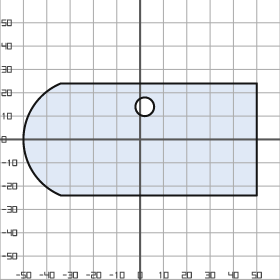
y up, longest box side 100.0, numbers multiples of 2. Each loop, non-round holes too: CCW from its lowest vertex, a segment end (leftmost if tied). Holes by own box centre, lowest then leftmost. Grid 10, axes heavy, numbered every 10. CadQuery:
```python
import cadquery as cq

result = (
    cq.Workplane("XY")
    .moveTo(-34.0, -24.0)
    .lineTo(50.0, -24.0)
    .lineTo(50.0, 24.0)
    .lineTo(-34.0, 24.0)
    .threePointArc((-50.0, 0.0), (-34.0, -24.0))
    .close()
    .moveTo(2.0, 14.0)
    .circle(4.0)
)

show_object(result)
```